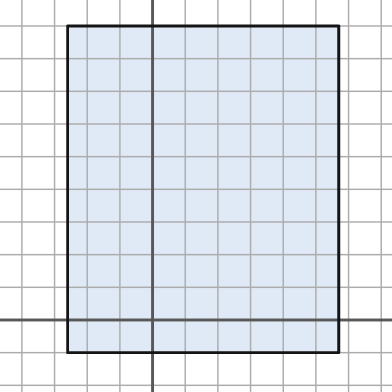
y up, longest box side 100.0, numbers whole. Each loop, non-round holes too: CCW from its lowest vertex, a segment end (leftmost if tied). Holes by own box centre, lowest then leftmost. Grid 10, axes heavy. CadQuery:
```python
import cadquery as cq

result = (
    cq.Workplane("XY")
    .moveTo(-26.0, -10.0)
    .lineTo(57.0, -10.0)
    .lineTo(57.0, 90.0)
    .lineTo(-26.0, 90.0)
    .close()
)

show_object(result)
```